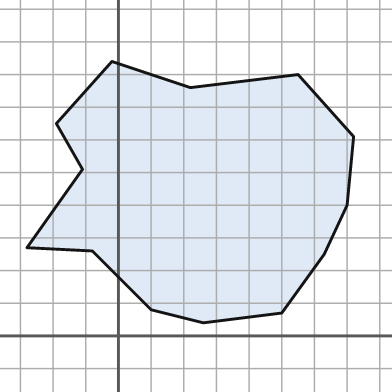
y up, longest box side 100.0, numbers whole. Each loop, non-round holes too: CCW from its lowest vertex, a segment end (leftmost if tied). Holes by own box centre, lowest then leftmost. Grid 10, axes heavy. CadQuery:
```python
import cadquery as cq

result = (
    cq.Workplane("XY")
    .moveTo(26.0, 4.0)
    .lineTo(50.0, 7.0)
    .lineTo(63.0, 25.0)
    .lineTo(70.0, 40.0)
    .lineTo(72.0, 61.0)
    .lineTo(55.0, 80.0)
    .lineTo(22.0, 76.0)
    .lineTo(-2.0, 84.0)
    .lineTo(-19.0, 65.0)
    .lineTo(-11.0, 51.0)
    .lineTo(-28.0, 27.0)
    .lineTo(-8.0, 26.0)
    .lineTo(10.0, 8.0)
    .close()
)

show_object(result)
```